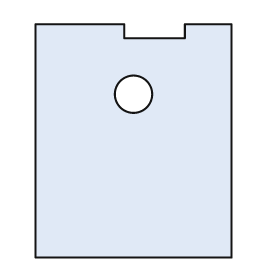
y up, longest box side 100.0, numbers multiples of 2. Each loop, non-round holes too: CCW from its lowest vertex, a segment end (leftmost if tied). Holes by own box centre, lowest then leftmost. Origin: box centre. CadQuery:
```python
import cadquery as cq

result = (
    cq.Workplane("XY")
    .moveTo(-42.0, -50.0)
    .lineTo(42.0, -50.0)
    .lineTo(42.0, 50.0)
    .lineTo(22.0, 50.0)
    .lineTo(22.0, 44.0)
    .lineTo(-4.0, 44.0)
    .lineTo(-4.0, 50.0)
    .lineTo(-42.0, 50.0)
    .close()
    .moveTo(0.0, 20.0)
    .circle(8.0)
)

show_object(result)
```